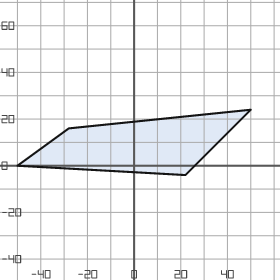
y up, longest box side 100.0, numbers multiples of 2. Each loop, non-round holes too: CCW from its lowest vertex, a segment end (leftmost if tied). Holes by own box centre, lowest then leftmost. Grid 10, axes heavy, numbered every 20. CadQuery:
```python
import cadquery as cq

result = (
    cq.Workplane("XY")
    .moveTo(22.0, -4.0)
    .lineTo(50.0, 24.0)
    .lineTo(-28.0, 16.0)
    .lineTo(-50.0, 0.0)
    .close()
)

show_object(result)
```